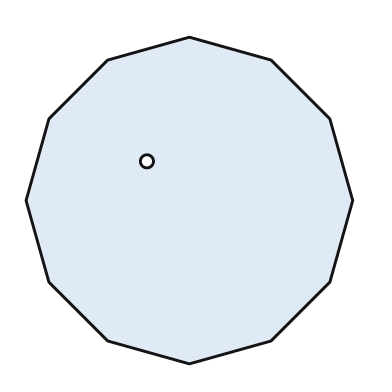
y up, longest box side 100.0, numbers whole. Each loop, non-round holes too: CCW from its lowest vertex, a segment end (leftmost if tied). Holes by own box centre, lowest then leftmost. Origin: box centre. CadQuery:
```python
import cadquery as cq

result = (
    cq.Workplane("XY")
    .moveTo(0.0, -50.0)
    .lineTo(25.0, -43.0)
    .lineTo(43.0, -25.0)
    .lineTo(50.0, 0.0)
    .lineTo(43.0, 25.0)
    .lineTo(25.0, 43.0)
    .lineTo(0.0, 50.0)
    .lineTo(-25.0, 43.0)
    .lineTo(-43.0, 25.0)
    .lineTo(-50.0, 0.0)
    .lineTo(-43.0, -25.0)
    .lineTo(-25.0, -43.0)
    .close()
    .moveTo(-13.0, 12.0)
    .circle(2.0)
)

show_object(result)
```